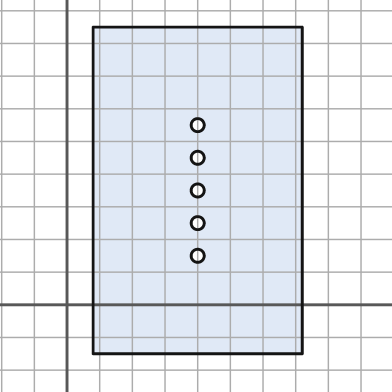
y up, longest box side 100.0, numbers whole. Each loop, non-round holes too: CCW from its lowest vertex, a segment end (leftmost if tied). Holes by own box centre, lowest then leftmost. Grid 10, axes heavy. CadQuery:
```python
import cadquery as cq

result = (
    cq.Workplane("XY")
    .moveTo(8.0, -15.0)
    .lineTo(72.0, -15.0)
    .lineTo(72.0, 85.0)
    .lineTo(8.0, 85.0)
    .close()
    .moveTo(40.0, 15.0)
    .circle(2.0)
    .moveTo(40.0, 25.0)
    .circle(2.0)
    .moveTo(40.0, 35.0)
    .circle(2.0)
    .moveTo(40.0, 45.0)
    .circle(2.0)
    .moveTo(40.0, 55.0)
    .circle(2.0)
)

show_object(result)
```